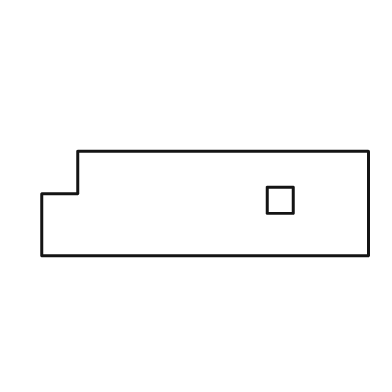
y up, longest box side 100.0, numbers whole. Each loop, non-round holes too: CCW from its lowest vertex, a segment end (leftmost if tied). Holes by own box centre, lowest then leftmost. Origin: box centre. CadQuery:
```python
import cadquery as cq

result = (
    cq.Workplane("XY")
    .moveTo(-50.0, -16.0)
    .lineTo(50.0, -16.0)
    .lineTo(50.0, 16.0)
    .lineTo(-39.0, 16.0)
    .lineTo(-39.0, 3.0)
    .lineTo(-50.0, 3.0)
    .close()
    .moveTo(19.0, -3.0)
    .lineTo(27.0, -3.0)
    .lineTo(27.0, 5.0)
    .lineTo(19.0, 5.0)
    .close()
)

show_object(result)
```